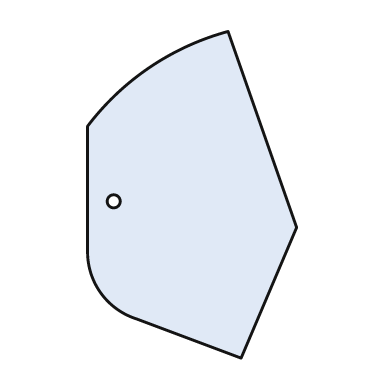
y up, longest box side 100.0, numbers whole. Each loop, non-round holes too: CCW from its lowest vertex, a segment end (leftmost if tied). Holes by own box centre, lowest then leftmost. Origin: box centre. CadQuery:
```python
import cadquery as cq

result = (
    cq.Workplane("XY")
    .moveTo(15.0, -50.0)
    .lineTo(32.0, -10.0)
    .lineTo(11.0, 50.0)
    .threePointArc((-13.0, 39.0), (-32.0, 21.0))
    .lineTo(-32.0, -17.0)
    .threePointArc((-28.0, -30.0), (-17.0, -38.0))
    .close()
    .moveTo(-24.0, -2.0)
    .circle(2.0)
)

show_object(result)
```